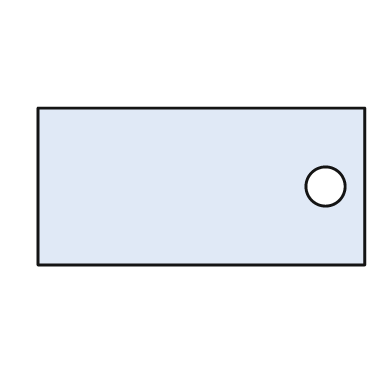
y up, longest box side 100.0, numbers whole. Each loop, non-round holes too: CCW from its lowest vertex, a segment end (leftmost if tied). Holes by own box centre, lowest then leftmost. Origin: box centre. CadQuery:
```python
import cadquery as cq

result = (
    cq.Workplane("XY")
    .moveTo(-50.0, -24.0)
    .lineTo(50.0, -24.0)
    .lineTo(50.0, 24.0)
    .lineTo(-50.0, 24.0)
    .close()
    .moveTo(38.0, 0.0)
    .circle(6.0)
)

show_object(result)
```